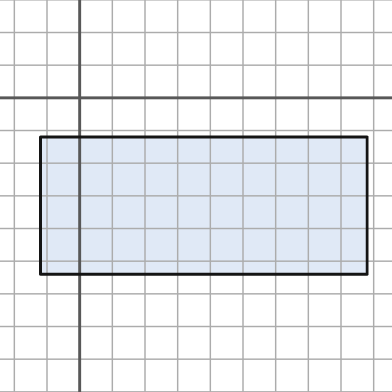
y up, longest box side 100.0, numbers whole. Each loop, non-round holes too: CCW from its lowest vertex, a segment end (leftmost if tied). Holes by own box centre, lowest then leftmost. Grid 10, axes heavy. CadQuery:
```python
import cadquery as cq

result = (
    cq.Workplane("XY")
    .moveTo(-12.0, -54.0)
    .lineTo(88.0, -54.0)
    .lineTo(88.0, -12.0)
    .lineTo(-12.0, -12.0)
    .close()
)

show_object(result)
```